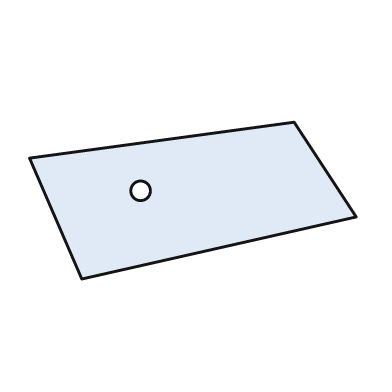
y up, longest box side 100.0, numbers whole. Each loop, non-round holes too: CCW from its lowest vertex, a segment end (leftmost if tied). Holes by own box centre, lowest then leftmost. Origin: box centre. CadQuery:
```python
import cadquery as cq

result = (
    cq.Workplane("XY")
    .moveTo(-34.0, -24.0)
    .lineTo(50.0, -5.0)
    .lineTo(31.0, 24.0)
    .lineTo(-50.0, 13.0)
    .close()
    .moveTo(-16.0, 3.0)
    .circle(3.0)
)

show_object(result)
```